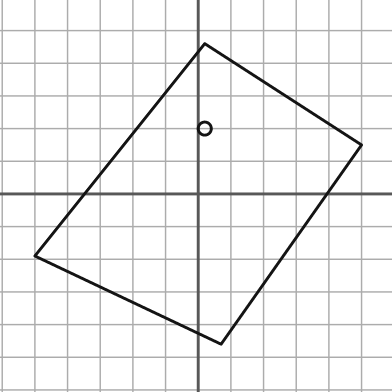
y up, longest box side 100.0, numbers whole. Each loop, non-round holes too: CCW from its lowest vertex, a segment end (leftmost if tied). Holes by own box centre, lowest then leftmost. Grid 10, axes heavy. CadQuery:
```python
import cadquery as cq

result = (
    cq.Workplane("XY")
    .moveTo(7.0, -46.0)
    .lineTo(50.0, 15.0)
    .lineTo(2.0, 46.0)
    .lineTo(-50.0, -19.0)
    .close()
    .moveTo(2.0, 20.0)
    .circle(2.0)
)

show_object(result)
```